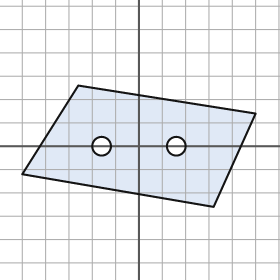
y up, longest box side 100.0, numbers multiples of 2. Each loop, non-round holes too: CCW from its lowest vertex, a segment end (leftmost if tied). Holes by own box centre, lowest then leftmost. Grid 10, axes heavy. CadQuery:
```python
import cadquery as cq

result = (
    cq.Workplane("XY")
    .moveTo(32.0, -26.0)
    .lineTo(50.0, 14.0)
    .lineTo(-26.0, 26.0)
    .lineTo(-50.0, -12.0)
    .close()
    .moveTo(-16.0, 0.0)
    .circle(4.0)
    .moveTo(16.0, 0.0)
    .circle(4.0)
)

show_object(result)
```